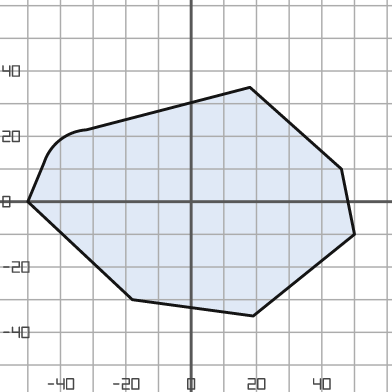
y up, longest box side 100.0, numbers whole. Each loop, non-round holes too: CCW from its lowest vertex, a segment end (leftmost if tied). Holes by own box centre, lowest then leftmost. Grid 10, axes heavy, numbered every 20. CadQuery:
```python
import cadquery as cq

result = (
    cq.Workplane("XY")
    .moveTo(19.0, -35.0)
    .lineTo(50.0, -10.0)
    .lineTo(46.0, 10.0)
    .lineTo(18.0, 35.0)
    .lineTo(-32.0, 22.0)
    .threePointArc((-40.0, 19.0), (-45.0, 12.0))
    .lineTo(-50.0, 0.0)
    .lineTo(-18.0, -30.0)
    .close()
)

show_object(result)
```